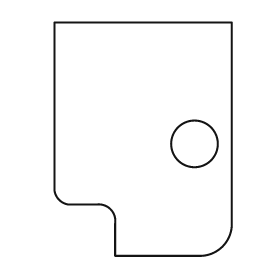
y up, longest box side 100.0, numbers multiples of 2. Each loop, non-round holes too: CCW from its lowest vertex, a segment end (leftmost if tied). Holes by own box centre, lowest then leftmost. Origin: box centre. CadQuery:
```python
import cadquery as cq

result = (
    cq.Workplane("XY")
    .moveTo(-12.0, -50.0)
    .lineTo(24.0, -50.0)
    .threePointArc((34.0, -46.0), (38.0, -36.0))
    .lineTo(38.0, 50.0)
    .lineTo(-38.0, 50.0)
    .lineTo(-38.0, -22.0)
    .threePointArc((-36.0, -26.0), (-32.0, -28.0))
    .lineTo(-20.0, -28.0)
    .threePointArc((-14.0, -30.0), (-12.0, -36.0))
    .close()
    .moveTo(22.0, -2.0)
    .circle(10.0)
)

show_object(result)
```